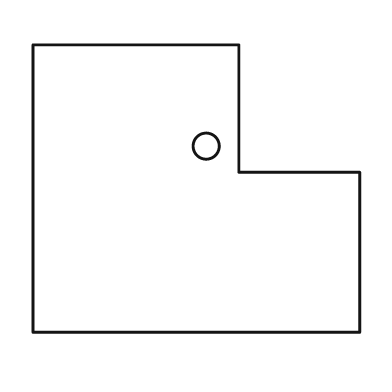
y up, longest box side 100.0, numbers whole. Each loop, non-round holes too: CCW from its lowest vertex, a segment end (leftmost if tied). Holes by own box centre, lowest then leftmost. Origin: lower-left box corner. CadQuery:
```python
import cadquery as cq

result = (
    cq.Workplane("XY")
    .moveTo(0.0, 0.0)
    .lineTo(100.0, 0.0)
    .lineTo(100.0, 49.0)
    .lineTo(63.0, 49.0)
    .lineTo(63.0, 88.0)
    .lineTo(0.0, 88.0)
    .close()
    .moveTo(53.0, 57.0)
    .circle(4.0)
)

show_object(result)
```